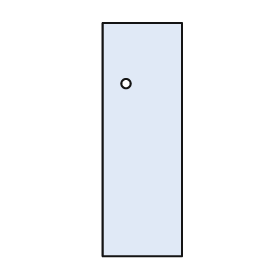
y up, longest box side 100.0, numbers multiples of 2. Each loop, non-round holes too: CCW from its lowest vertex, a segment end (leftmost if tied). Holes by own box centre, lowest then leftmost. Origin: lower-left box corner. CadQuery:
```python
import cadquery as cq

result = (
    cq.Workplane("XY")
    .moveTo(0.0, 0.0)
    .lineTo(34.0, 0.0)
    .lineTo(34.0, 100.0)
    .lineTo(0.0, 100.0)
    .close()
    .moveTo(10.0, 74.0)
    .circle(2.0)
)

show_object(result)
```